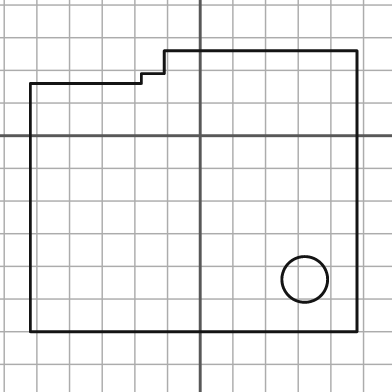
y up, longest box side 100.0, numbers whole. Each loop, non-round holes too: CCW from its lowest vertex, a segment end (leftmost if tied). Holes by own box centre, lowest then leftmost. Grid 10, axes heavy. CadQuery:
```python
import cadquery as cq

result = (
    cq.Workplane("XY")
    .moveTo(-52.0, -60.0)
    .lineTo(48.0, -60.0)
    .lineTo(48.0, 26.0)
    .lineTo(-11.0, 26.0)
    .lineTo(-11.0, 19.0)
    .lineTo(-18.0, 19.0)
    .lineTo(-18.0, 16.0)
    .lineTo(-52.0, 16.0)
    .close()
    .moveTo(32.0, -44.0)
    .circle(7.0)
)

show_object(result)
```